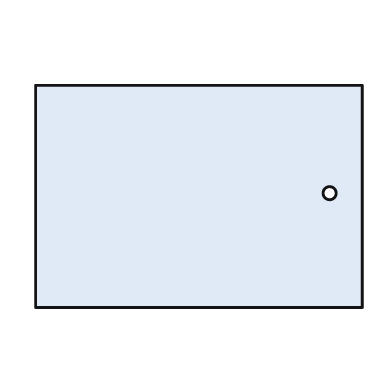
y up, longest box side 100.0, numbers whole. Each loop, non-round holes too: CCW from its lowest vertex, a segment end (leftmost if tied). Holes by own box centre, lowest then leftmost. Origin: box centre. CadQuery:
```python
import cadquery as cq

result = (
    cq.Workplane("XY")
    .moveTo(-50.0, -34.0)
    .lineTo(50.0, -34.0)
    .lineTo(50.0, 34.0)
    .lineTo(-50.0, 34.0)
    .close()
    .moveTo(40.0, 1.0)
    .circle(2.0)
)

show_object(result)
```